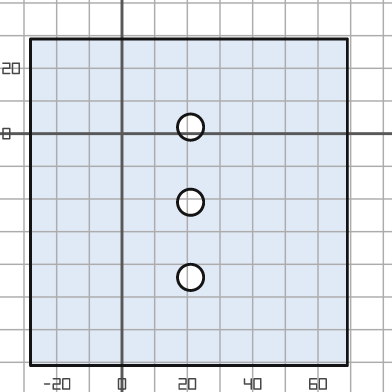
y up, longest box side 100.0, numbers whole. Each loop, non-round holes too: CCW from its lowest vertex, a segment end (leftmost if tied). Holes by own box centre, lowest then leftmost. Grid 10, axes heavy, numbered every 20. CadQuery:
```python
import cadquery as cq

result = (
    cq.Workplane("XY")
    .moveTo(-28.0, -71.0)
    .lineTo(69.0, -71.0)
    .lineTo(69.0, 29.0)
    .lineTo(-28.0, 29.0)
    .close()
    .moveTo(21.0, -44.0)
    .circle(4.0)
    .moveTo(21.0, -21.0)
    .circle(4.0)
    .moveTo(21.0, 2.0)
    .circle(4.0)
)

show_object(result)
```